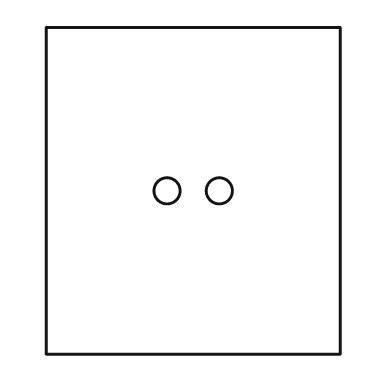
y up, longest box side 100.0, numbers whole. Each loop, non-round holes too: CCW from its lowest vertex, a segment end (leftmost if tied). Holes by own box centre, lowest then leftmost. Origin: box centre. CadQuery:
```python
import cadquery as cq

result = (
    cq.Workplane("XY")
    .moveTo(-45.0, -50.0)
    .lineTo(45.0, -50.0)
    .lineTo(45.0, 50.0)
    .lineTo(-45.0, 50.0)
    .close()
    .moveTo(-8.0, 0.0)
    .circle(4.0)
    .moveTo(8.0, 0.0)
    .circle(4.0)
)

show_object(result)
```